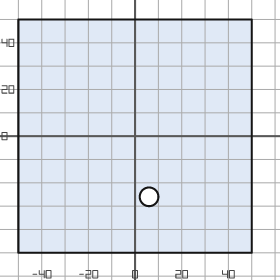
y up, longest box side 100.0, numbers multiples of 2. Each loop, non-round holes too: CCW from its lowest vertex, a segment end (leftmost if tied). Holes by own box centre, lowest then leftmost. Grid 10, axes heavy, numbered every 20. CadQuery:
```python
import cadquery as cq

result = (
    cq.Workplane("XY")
    .moveTo(-50.0, -50.0)
    .lineTo(50.0, -50.0)
    .lineTo(50.0, 50.0)
    .lineTo(-50.0, 50.0)
    .close()
    .moveTo(6.0, -26.0)
    .circle(4.0)
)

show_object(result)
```